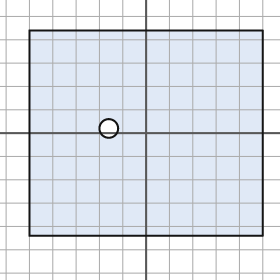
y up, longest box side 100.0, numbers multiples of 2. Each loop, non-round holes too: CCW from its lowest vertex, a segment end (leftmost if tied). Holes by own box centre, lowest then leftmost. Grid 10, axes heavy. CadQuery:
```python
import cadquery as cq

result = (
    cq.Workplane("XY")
    .moveTo(-50.0, -44.0)
    .lineTo(50.0, -44.0)
    .lineTo(50.0, 44.0)
    .lineTo(-50.0, 44.0)
    .close()
    .moveTo(-16.0, 2.0)
    .circle(4.0)
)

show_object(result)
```